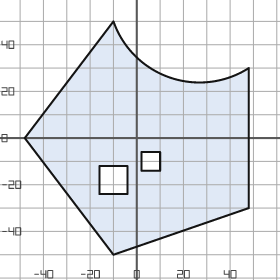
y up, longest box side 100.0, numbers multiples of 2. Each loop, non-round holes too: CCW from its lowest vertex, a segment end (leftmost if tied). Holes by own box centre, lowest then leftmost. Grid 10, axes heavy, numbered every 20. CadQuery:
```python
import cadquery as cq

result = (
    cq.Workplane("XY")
    .moveTo(-10.0, -50.0)
    .lineTo(48.0, -30.0)
    .lineTo(48.0, 30.0)
    .threePointArc((14.0, 26.0), (-10.0, 50.0))
    .lineTo(-48.0, 0.0)
    .close()
    .moveTo(-16.0, -24.0)
    .lineTo(-4.0, -24.0)
    .lineTo(-4.0, -12.0)
    .lineTo(-16.0, -12.0)
    .close()
    .moveTo(2.0, -14.0)
    .lineTo(10.0, -14.0)
    .lineTo(10.0, -6.0)
    .lineTo(2.0, -6.0)
    .close()
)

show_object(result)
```